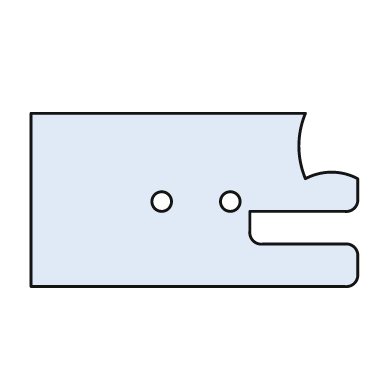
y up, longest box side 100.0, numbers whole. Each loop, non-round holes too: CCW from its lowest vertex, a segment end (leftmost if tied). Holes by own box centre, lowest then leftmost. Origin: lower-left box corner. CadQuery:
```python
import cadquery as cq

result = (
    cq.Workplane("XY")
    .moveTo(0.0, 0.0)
    .lineTo(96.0, 0.0)
    .threePointArc((99.0, 1.0), (100.0, 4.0))
    .lineTo(100.0, 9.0)
    .threePointArc((99.0, 12.0), (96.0, 13.0))
    .lineTo(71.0, 13.0)
    .threePointArc((68.0, 14.0), (67.0, 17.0))
    .lineTo(67.0, 23.0)
    .lineTo(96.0, 23.0)
    .threePointArc((99.0, 24.0), (100.0, 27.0))
    .lineTo(100.0, 33.0)
    .threePointArc((92.0, 35.0), (84.0, 33.0))
    .threePointArc((82.0, 43.0), (84.0, 53.0))
    .lineTo(0.0, 53.0)
    .close()
    .moveTo(40.0, 26.0)
    .circle(3.0)
    .moveTo(61.0, 26.0)
    .circle(3.0)
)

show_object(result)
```